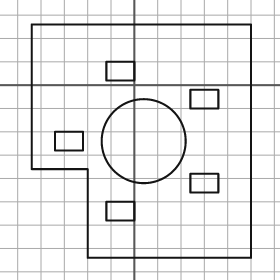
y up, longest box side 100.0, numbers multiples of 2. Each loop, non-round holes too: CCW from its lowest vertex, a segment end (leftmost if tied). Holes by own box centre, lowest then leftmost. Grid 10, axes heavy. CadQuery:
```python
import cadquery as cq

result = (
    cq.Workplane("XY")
    .moveTo(-20.0, -74.0)
    .lineTo(50.0, -74.0)
    .lineTo(50.0, 26.0)
    .lineTo(-44.0, 26.0)
    .lineTo(-44.0, -36.0)
    .lineTo(-20.0, -36.0)
    .close()
    .moveTo(-12.0, -58.0)
    .lineTo(0.0, -58.0)
    .lineTo(0.0, -50.0)
    .lineTo(-12.0, -50.0)
    .close()
    .moveTo(24.0, -46.0)
    .lineTo(36.0, -46.0)
    .lineTo(36.0, -38.0)
    .lineTo(24.0, -38.0)
    .close()
    .moveTo(-34.0, -28.0)
    .lineTo(-22.0, -28.0)
    .lineTo(-22.0, -20.0)
    .lineTo(-34.0, -20.0)
    .close()
    .moveTo(4.0, -24.0)
    .circle(18.0)
    .moveTo(24.0, -10.0)
    .lineTo(36.0, -10.0)
    .lineTo(36.0, -2.0)
    .lineTo(24.0, -2.0)
    .close()
    .moveTo(-12.0, 2.0)
    .lineTo(0.0, 2.0)
    .lineTo(0.0, 10.0)
    .lineTo(-12.0, 10.0)
    .close()
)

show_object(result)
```